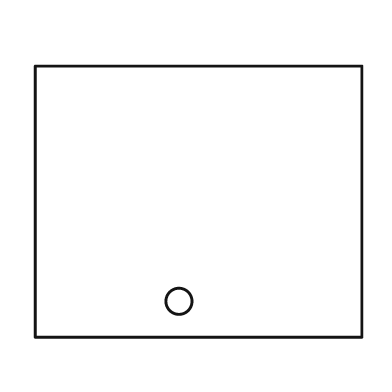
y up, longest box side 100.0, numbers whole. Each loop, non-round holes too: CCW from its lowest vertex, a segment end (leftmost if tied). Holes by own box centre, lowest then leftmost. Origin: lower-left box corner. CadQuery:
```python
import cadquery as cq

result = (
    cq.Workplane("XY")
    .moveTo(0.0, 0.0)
    .lineTo(100.0, 0.0)
    .lineTo(100.0, 83.0)
    .lineTo(0.0, 83.0)
    .close()
    .moveTo(44.0, 11.0)
    .circle(4.0)
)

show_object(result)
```